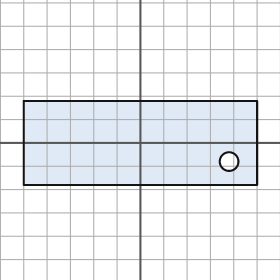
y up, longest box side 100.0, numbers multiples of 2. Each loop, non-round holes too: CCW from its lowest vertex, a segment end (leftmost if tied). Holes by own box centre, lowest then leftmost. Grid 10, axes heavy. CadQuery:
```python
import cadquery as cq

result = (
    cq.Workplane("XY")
    .moveTo(-50.0, -18.0)
    .lineTo(50.0, -18.0)
    .lineTo(50.0, 18.0)
    .lineTo(-50.0, 18.0)
    .close()
    .moveTo(38.0, -8.0)
    .circle(4.0)
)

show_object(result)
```